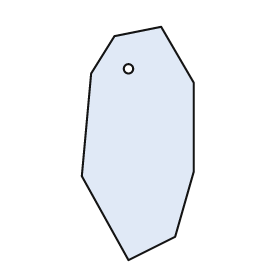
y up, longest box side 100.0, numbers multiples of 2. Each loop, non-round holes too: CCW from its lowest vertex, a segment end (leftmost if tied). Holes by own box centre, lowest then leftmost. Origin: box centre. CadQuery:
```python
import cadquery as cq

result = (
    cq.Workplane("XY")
    .moveTo(-4.0, -50.0)
    .lineTo(16.0, -40.0)
    .lineTo(24.0, -12.0)
    .lineTo(24.0, 26.0)
    .lineTo(10.0, 50.0)
    .lineTo(-10.0, 46.0)
    .lineTo(-20.0, 30.0)
    .lineTo(-24.0, -14.0)
    .close()
    .moveTo(-4.0, 32.0)
    .circle(2.0)
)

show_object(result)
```